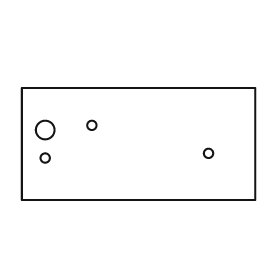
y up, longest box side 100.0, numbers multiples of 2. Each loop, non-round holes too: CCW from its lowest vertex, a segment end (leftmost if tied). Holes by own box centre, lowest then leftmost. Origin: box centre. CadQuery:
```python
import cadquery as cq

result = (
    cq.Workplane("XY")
    .moveTo(-50.0, -24.0)
    .lineTo(50.0, -24.0)
    .lineTo(50.0, 24.0)
    .lineTo(-50.0, 24.0)
    .close()
    .moveTo(-40.0, -6.0)
    .circle(2.0)
    .moveTo(30.0, -4.0)
    .circle(2.0)
    .moveTo(-40.0, 6.0)
    .circle(4.0)
    .moveTo(-20.0, 8.0)
    .circle(2.0)
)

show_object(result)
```